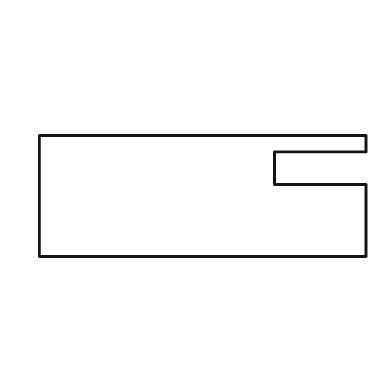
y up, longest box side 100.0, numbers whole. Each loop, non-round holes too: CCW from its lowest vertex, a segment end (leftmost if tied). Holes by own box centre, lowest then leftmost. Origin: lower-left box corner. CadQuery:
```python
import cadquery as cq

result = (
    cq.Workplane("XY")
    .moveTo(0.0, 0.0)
    .lineTo(100.0, 0.0)
    .lineTo(100.0, 22.0)
    .lineTo(72.0, 22.0)
    .lineTo(72.0, 32.0)
    .lineTo(100.0, 32.0)
    .lineTo(100.0, 37.0)
    .lineTo(0.0, 37.0)
    .close()
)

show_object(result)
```